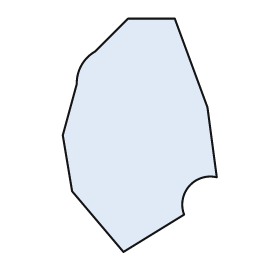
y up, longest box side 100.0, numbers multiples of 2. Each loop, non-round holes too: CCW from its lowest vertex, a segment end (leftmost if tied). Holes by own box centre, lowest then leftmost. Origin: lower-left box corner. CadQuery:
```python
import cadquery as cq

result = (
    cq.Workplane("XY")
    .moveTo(26.0, 0.0)
    .lineTo(52.0, 16.0)
    .threePointArc((54.0, 28.0), (66.0, 32.0))
    .lineTo(62.0, 62.0)
    .lineTo(48.0, 100.0)
    .lineTo(28.0, 100.0)
    .lineTo(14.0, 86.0)
    .threePointArc((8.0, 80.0), (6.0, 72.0))
    .lineTo(0.0, 50.0)
    .lineTo(4.0, 26.0)
    .close()
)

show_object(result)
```